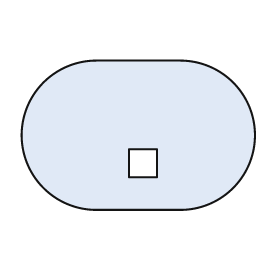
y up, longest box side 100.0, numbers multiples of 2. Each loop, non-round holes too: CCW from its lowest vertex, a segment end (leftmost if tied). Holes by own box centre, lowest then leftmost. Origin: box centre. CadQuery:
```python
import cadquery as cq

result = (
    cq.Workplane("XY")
    .moveTo(-18.0, -32.0)
    .lineTo(18.0, -32.0)
    .threePointArc((50.0, 0.0), (18.0, 32.0))
    .lineTo(-18.0, 32.0)
    .threePointArc((-50.0, 0.0), (-18.0, -32.0))
    .close()
    .moveTo(-4.0, -18.0)
    .lineTo(8.0, -18.0)
    .lineTo(8.0, -6.0)
    .lineTo(-4.0, -6.0)
    .close()
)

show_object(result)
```